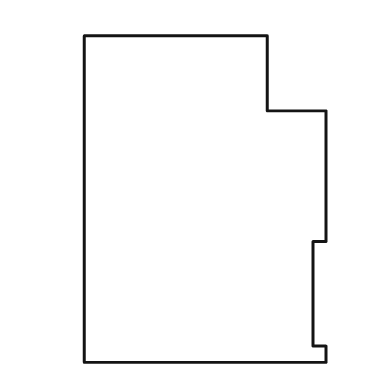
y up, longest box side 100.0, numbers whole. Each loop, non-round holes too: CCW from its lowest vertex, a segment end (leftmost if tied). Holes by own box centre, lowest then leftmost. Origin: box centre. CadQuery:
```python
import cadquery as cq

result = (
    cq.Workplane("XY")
    .moveTo(-37.0, -50.0)
    .lineTo(37.0, -50.0)
    .lineTo(37.0, -45.0)
    .lineTo(33.0, -45.0)
    .lineTo(33.0, -13.0)
    .lineTo(37.0, -13.0)
    .lineTo(37.0, 27.0)
    .lineTo(19.0, 27.0)
    .lineTo(19.0, 50.0)
    .lineTo(-37.0, 50.0)
    .close()
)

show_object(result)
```